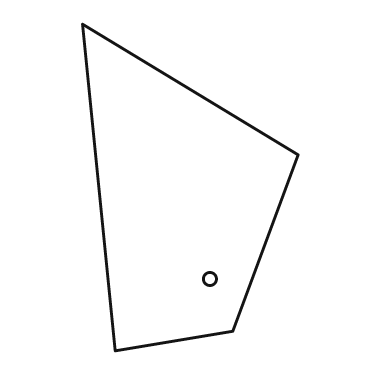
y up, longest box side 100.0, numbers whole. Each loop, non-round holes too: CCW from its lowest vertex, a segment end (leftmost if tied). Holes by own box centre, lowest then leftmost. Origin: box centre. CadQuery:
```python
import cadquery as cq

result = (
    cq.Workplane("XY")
    .moveTo(-23.0, -50.0)
    .lineTo(13.0, -44.0)
    .lineTo(33.0, 10.0)
    .lineTo(-33.0, 50.0)
    .close()
    .moveTo(6.0, -28.0)
    .circle(2.0)
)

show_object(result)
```